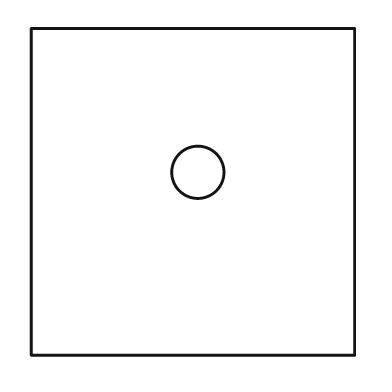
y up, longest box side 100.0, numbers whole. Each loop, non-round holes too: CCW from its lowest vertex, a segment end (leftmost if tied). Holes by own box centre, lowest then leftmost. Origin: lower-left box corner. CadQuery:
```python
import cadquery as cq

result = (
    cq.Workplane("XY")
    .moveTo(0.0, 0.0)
    .lineTo(99.0, 0.0)
    .lineTo(99.0, 100.0)
    .lineTo(0.0, 100.0)
    .close()
    .moveTo(51.0, 56.0)
    .circle(8.0)
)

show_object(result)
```